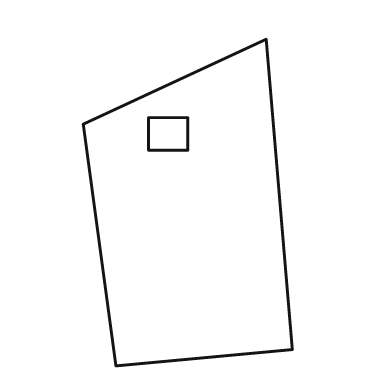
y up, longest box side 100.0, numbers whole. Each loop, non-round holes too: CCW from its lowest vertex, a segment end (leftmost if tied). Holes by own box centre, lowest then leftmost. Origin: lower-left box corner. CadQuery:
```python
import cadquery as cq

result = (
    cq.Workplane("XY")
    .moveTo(10.0, 0.0)
    .lineTo(64.0, 5.0)
    .lineTo(56.0, 100.0)
    .lineTo(0.0, 74.0)
    .close()
    .moveTo(20.0, 66.0)
    .lineTo(32.0, 66.0)
    .lineTo(32.0, 76.0)
    .lineTo(20.0, 76.0)
    .close()
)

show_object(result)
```